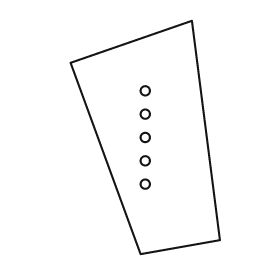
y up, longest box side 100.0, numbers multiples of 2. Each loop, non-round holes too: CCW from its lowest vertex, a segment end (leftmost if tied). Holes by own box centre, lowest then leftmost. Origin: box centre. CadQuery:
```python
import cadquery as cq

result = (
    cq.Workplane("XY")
    .moveTo(-2.0, -50.0)
    .lineTo(32.0, -44.0)
    .lineTo(20.0, 50.0)
    .lineTo(-32.0, 32.0)
    .close()
    .moveTo(0.0, -20.0)
    .circle(2.0)
    .moveTo(0.0, -10.0)
    .circle(2.0)
    .moveTo(0.0, 0.0)
    .circle(2.0)
    .moveTo(0.0, 10.0)
    .circle(2.0)
    .moveTo(0.0, 20.0)
    .circle(2.0)
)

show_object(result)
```